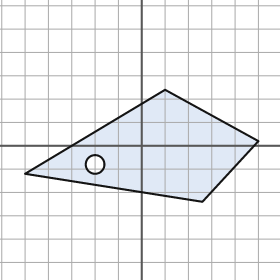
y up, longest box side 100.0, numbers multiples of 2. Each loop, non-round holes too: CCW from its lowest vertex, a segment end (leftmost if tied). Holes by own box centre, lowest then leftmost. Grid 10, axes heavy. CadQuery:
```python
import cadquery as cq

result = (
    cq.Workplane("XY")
    .moveTo(26.0, -24.0)
    .lineTo(50.0, 2.0)
    .lineTo(10.0, 24.0)
    .lineTo(-50.0, -12.0)
    .close()
    .moveTo(-20.0, -8.0)
    .circle(4.0)
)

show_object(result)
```